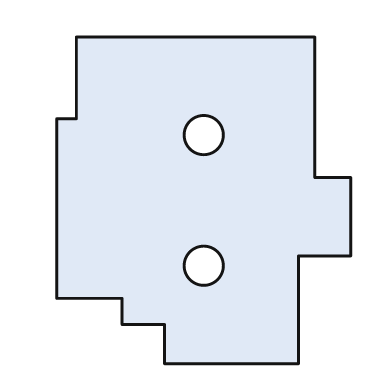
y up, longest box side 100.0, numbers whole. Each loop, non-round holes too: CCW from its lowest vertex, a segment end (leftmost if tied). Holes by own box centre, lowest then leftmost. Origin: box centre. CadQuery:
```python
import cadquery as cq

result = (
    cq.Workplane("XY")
    .moveTo(-12.0, -50.0)
    .lineTo(29.0, -50.0)
    .lineTo(29.0, -17.0)
    .lineTo(45.0, -17.0)
    .lineTo(45.0, 7.0)
    .lineTo(34.0, 7.0)
    .lineTo(34.0, 50.0)
    .lineTo(-39.0, 50.0)
    .lineTo(-39.0, 25.0)
    .lineTo(-45.0, 25.0)
    .lineTo(-45.0, -30.0)
    .lineTo(-25.0, -30.0)
    .lineTo(-25.0, -38.0)
    .lineTo(-12.0, -38.0)
    .close()
    .moveTo(0.0, -20.0)
    .circle(6.0)
    .moveTo(0.0, 20.0)
    .circle(6.0)
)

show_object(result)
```